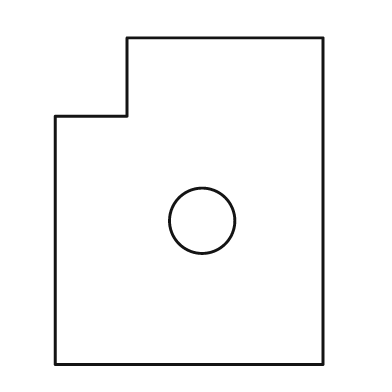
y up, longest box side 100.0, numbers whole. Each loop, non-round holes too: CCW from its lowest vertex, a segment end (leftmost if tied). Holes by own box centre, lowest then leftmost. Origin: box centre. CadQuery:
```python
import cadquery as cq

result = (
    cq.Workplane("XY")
    .moveTo(-41.0, -50.0)
    .lineTo(41.0, -50.0)
    .lineTo(41.0, 50.0)
    .lineTo(-19.0, 50.0)
    .lineTo(-19.0, 26.0)
    .lineTo(-41.0, 26.0)
    .close()
    .moveTo(4.0, -6.0)
    .circle(10.0)
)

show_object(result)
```